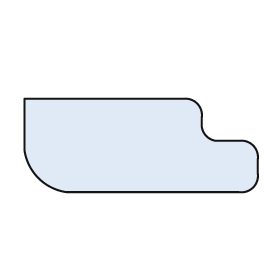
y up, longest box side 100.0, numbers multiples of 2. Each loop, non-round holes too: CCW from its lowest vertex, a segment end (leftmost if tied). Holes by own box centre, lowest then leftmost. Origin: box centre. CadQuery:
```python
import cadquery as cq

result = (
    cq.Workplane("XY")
    .moveTo(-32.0, -20.0)
    .lineTo(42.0, -20.0)
    .threePointArc((48.0, -18.0), (50.0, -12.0))
    .lineTo(50.0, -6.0)
    .threePointArc((48.0, 0.0), (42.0, 2.0))
    .lineTo(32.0, 2.0)
    .threePointArc((28.0, 4.0), (26.0, 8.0))
    .lineTo(26.0, 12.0)
    .threePointArc((24.0, 18.0), (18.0, 20.0))
    .lineTo(-50.0, 20.0)
    .lineTo(-50.0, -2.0)
    .threePointArc((-44.0, -14.0), (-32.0, -20.0))
    .close()
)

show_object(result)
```